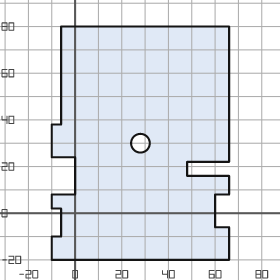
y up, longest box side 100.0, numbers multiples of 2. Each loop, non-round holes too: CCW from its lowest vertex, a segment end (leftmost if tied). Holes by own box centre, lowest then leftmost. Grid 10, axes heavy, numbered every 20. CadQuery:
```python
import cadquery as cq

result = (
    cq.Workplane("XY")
    .moveTo(-10.0, -20.0)
    .lineTo(66.0, -20.0)
    .lineTo(66.0, -6.0)
    .lineTo(60.0, -6.0)
    .lineTo(60.0, 8.0)
    .lineTo(66.0, 8.0)
    .lineTo(66.0, 16.0)
    .lineTo(48.0, 16.0)
    .lineTo(48.0, 22.0)
    .lineTo(66.0, 22.0)
    .lineTo(66.0, 80.0)
    .lineTo(-6.0, 80.0)
    .lineTo(-6.0, 38.0)
    .lineTo(-10.0, 38.0)
    .lineTo(-10.0, 24.0)
    .lineTo(0.0, 24.0)
    .lineTo(0.0, 8.0)
    .lineTo(-10.0, 8.0)
    .lineTo(-10.0, 2.0)
    .lineTo(-6.0, 2.0)
    .lineTo(-6.0, -10.0)
    .lineTo(-10.0, -10.0)
    .close()
    .moveTo(28.0, 30.0)
    .circle(4.0)
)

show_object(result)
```